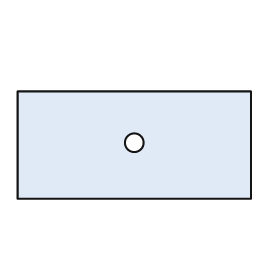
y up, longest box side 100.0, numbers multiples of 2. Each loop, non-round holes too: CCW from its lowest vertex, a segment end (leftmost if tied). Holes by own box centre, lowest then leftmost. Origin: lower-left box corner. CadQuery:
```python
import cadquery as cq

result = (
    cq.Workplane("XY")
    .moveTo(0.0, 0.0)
    .lineTo(100.0, 0.0)
    .lineTo(100.0, 46.0)
    .lineTo(0.0, 46.0)
    .close()
    .moveTo(50.0, 24.0)
    .circle(4.0)
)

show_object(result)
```